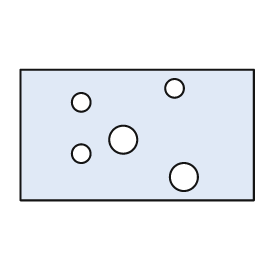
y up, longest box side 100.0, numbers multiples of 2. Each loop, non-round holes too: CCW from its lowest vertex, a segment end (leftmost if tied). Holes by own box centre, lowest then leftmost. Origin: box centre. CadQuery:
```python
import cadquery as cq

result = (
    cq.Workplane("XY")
    .moveTo(-50.0, -28.0)
    .lineTo(50.0, -28.0)
    .lineTo(50.0, 28.0)
    .lineTo(-50.0, 28.0)
    .close()
    .moveTo(20.0, -18.0)
    .circle(6.0)
    .moveTo(-24.0, -8.0)
    .circle(4.0)
    .moveTo(-6.0, -2.0)
    .circle(6.0)
    .moveTo(-24.0, 14.0)
    .circle(4.0)
    .moveTo(16.0, 20.0)
    .circle(4.0)
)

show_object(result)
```